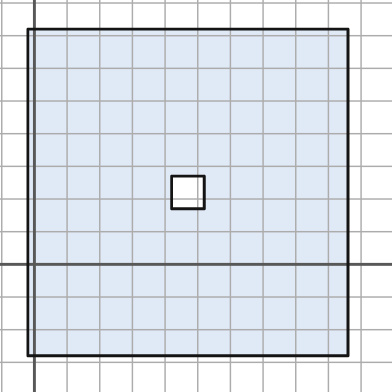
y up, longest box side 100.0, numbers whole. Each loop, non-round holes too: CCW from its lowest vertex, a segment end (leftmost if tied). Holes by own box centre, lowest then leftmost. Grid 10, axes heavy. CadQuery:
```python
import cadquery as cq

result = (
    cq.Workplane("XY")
    .moveTo(-2.0, -28.0)
    .lineTo(96.0, -28.0)
    .lineTo(96.0, 72.0)
    .lineTo(-2.0, 72.0)
    .close()
    .moveTo(42.0, 17.0)
    .lineTo(52.0, 17.0)
    .lineTo(52.0, 27.0)
    .lineTo(42.0, 27.0)
    .close()
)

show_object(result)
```